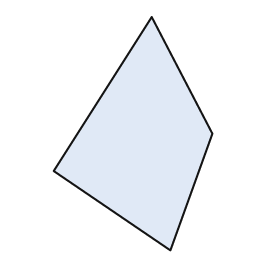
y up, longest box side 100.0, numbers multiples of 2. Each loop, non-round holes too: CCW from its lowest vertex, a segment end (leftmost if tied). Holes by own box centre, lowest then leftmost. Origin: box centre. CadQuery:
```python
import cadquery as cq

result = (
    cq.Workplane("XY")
    .moveTo(16.0, -50.0)
    .lineTo(34.0, 0.0)
    .lineTo(8.0, 50.0)
    .lineTo(-34.0, -16.0)
    .close()
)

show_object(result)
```